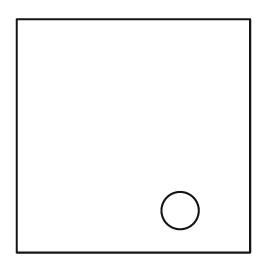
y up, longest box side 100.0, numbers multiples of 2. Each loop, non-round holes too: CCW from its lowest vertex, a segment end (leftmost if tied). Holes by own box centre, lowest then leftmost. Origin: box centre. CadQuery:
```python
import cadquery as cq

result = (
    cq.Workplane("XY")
    .moveTo(-50.0, -50.0)
    .lineTo(50.0, -50.0)
    .lineTo(50.0, 50.0)
    .lineTo(-50.0, 50.0)
    .close()
    .moveTo(20.0, -32.0)
    .circle(8.0)
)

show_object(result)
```